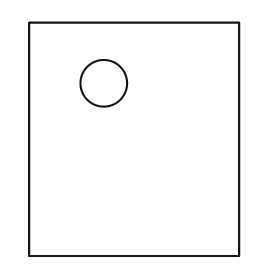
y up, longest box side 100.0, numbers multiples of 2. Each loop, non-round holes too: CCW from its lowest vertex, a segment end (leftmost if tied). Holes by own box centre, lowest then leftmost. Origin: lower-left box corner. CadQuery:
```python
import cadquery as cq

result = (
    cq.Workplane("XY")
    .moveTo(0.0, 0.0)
    .lineTo(90.0, 0.0)
    .lineTo(90.0, 100.0)
    .lineTo(0.0, 100.0)
    .close()
    .moveTo(32.0, 74.0)
    .circle(10.0)
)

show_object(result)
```